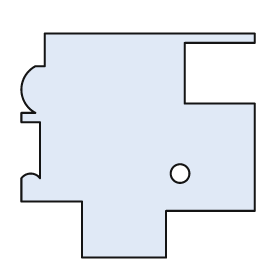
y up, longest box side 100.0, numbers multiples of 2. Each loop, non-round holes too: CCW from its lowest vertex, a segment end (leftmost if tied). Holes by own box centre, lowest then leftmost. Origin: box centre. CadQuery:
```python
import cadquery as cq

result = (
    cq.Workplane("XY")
    .moveTo(-24.0, -48.0)
    .lineTo(12.0, -48.0)
    .lineTo(12.0, -28.0)
    .lineTo(50.0, -28.0)
    .lineTo(50.0, 18.0)
    .lineTo(20.0, 18.0)
    .lineTo(20.0, 44.0)
    .lineTo(50.0, 44.0)
    .lineTo(50.0, 48.0)
    .lineTo(-40.0, 48.0)
    .lineTo(-40.0, 34.0)
    .lineTo(-44.0, 34.0)
    .threePointArc((-50.0, 24.0), (-44.0, 14.0))
    .lineTo(-50.0, 14.0)
    .lineTo(-50.0, 10.0)
    .lineTo(-42.0, 10.0)
    .lineTo(-42.0, -14.0)
    .threePointArc((-46.0, -12.0), (-50.0, -14.0))
    .lineTo(-50.0, -24.0)
    .lineTo(-24.0, -24.0)
    .close()
    .moveTo(18.0, -12.0)
    .circle(4.0)
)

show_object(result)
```